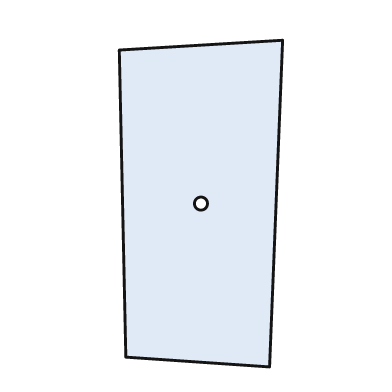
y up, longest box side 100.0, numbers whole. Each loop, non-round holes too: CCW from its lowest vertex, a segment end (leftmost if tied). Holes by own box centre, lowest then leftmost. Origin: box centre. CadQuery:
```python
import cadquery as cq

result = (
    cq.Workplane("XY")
    .moveTo(21.0, -50.0)
    .lineTo(25.0, 50.0)
    .lineTo(-25.0, 47.0)
    .lineTo(-23.0, -47.0)
    .close()
    .moveTo(0.0, 0.0)
    .circle(2.0)
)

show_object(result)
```